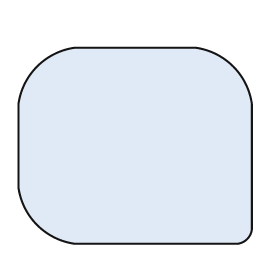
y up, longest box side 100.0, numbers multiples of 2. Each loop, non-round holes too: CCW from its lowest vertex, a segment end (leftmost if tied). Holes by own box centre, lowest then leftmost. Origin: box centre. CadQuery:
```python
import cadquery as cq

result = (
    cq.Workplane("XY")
    .moveTo(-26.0, -42.0)
    .lineTo(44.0, -42.0)
    .threePointArc((48.0, -40.0), (50.0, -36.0))
    .lineTo(50.0, 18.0)
    .threePointArc((42.0, 34.0), (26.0, 42.0))
    .lineTo(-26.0, 42.0)
    .threePointArc((-42.0, 34.0), (-50.0, 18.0))
    .lineTo(-50.0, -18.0)
    .threePointArc((-42.0, -34.0), (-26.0, -42.0))
    .close()
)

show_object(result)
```